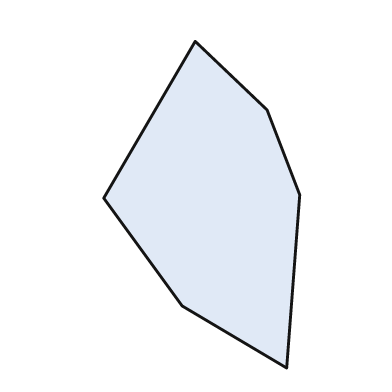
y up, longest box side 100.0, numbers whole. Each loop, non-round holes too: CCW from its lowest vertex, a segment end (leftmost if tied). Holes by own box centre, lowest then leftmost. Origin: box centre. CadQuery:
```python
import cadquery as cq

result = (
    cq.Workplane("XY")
    .moveTo(26.0, -50.0)
    .lineTo(30.0, 3.0)
    .lineTo(20.0, 29.0)
    .lineTo(-2.0, 50.0)
    .lineTo(-30.0, 2.0)
    .lineTo(-6.0, -31.0)
    .close()
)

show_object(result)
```